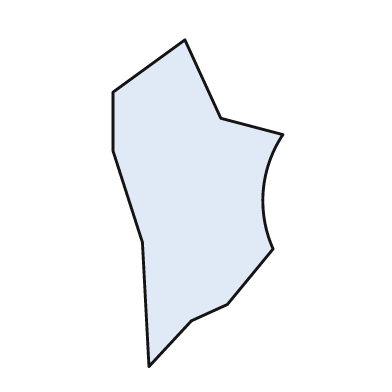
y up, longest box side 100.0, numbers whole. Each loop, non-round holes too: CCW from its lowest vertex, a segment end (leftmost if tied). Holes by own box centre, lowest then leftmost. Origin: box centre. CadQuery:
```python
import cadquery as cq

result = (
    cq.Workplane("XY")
    .moveTo(-15.0, -50.0)
    .lineTo(-2.0, -36.0)
    .lineTo(9.0, -31.0)
    .lineTo(23.0, -14.0)
    .threePointArc((20.0, 4.0), (26.0, 21.0))
    .lineTo(7.0, 26.0)
    .lineTo(-4.0, 50.0)
    .lineTo(-26.0, 34.0)
    .lineTo(-26.0, 16.0)
    .lineTo(-17.0, -12.0)
    .close()
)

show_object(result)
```